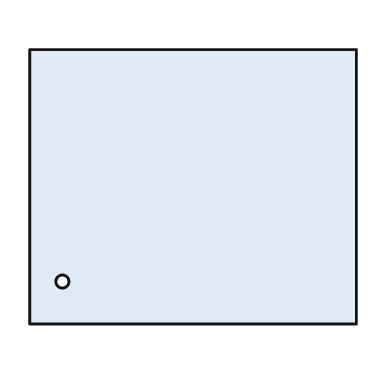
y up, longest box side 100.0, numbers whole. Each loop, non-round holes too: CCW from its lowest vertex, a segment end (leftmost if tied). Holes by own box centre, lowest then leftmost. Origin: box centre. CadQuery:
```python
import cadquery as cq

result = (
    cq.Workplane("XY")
    .moveTo(-50.0, -42.0)
    .lineTo(50.0, -42.0)
    .lineTo(50.0, 42.0)
    .lineTo(-50.0, 42.0)
    .close()
    .moveTo(-40.0, -29.0)
    .circle(2.0)
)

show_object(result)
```